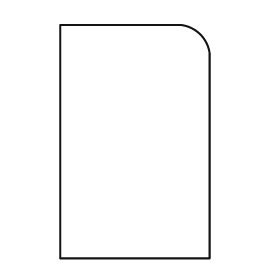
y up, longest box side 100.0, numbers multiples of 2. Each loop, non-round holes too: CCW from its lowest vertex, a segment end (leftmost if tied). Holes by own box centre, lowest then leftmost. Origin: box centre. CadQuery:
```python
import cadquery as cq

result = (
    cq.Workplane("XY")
    .moveTo(-32.0, -50.0)
    .lineTo(32.0, -50.0)
    .lineTo(32.0, 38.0)
    .threePointArc((28.0, 46.0), (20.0, 50.0))
    .lineTo(-32.0, 50.0)
    .close()
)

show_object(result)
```